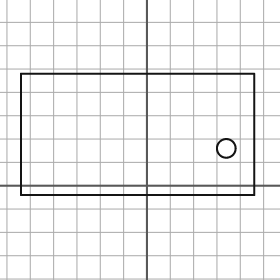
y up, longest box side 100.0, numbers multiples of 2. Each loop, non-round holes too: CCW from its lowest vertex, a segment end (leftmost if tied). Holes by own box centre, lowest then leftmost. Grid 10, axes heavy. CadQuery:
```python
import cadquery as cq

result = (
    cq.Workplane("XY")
    .moveTo(-54.0, -4.0)
    .lineTo(46.0, -4.0)
    .lineTo(46.0, 48.0)
    .lineTo(-54.0, 48.0)
    .close()
    .moveTo(34.0, 16.0)
    .circle(4.0)
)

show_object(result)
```